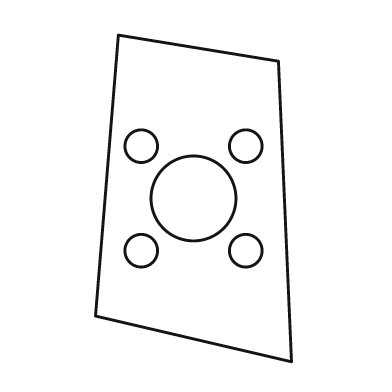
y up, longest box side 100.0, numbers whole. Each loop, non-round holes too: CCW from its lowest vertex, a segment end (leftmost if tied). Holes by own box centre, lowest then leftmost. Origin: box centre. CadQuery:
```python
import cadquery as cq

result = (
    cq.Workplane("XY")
    .moveTo(30.0, -50.0)
    .lineTo(26.0, 42.0)
    .lineTo(-23.0, 50.0)
    .lineTo(-30.0, -36.0)
    .close()
    .moveTo(-16.0, -16.0)
    .circle(5.0)
    .moveTo(16.0, -16.0)
    .circle(5.0)
    .moveTo(0.0, 0.0)
    .circle(13.0)
    .moveTo(-16.0, 16.0)
    .circle(5.0)
    .moveTo(16.0, 16.0)
    .circle(5.0)
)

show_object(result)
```